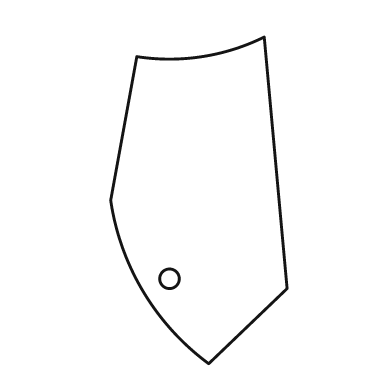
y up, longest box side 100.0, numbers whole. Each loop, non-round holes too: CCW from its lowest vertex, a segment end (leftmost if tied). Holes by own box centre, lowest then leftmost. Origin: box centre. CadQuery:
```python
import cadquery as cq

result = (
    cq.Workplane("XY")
    .moveTo(3.0, -50.0)
    .lineTo(27.0, -27.0)
    .lineTo(20.0, 50.0)
    .threePointArc((1.0, 44.0), (-19.0, 44.0))
    .lineTo(-27.0, 0.0)
    .threePointArc((-17.0, -28.0), (3.0, -50.0))
    .close()
    .moveTo(-9.0, -24.0)
    .circle(3.0)
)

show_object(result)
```